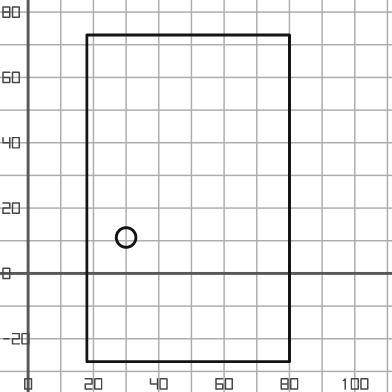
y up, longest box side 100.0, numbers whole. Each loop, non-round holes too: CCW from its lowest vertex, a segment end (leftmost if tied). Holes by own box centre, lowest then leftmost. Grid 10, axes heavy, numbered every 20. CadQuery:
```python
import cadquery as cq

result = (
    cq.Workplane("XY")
    .moveTo(18.0, -27.0)
    .lineTo(80.0, -27.0)
    .lineTo(80.0, 73.0)
    .lineTo(18.0, 73.0)
    .close()
    .moveTo(30.0, 11.0)
    .circle(3.0)
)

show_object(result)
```